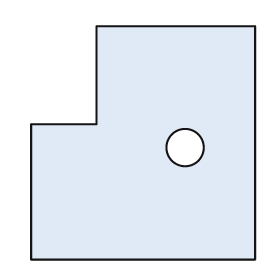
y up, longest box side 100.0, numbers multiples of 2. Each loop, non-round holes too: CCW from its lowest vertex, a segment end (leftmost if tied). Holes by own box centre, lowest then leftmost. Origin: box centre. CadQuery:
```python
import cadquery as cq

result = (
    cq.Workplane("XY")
    .moveTo(-48.0, -50.0)
    .lineTo(48.0, -50.0)
    .lineTo(48.0, 50.0)
    .lineTo(-20.0, 50.0)
    .lineTo(-20.0, 8.0)
    .lineTo(-48.0, 8.0)
    .close()
    .moveTo(18.0, -2.0)
    .circle(8.0)
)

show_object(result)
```